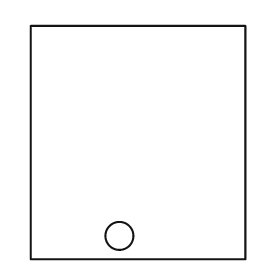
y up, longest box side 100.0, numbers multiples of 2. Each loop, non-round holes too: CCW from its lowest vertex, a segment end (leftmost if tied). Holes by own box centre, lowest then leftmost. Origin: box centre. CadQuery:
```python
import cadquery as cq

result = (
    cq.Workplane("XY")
    .moveTo(-46.0, -50.0)
    .lineTo(46.0, -50.0)
    .lineTo(46.0, 50.0)
    .lineTo(-46.0, 50.0)
    .close()
    .moveTo(-8.0, -40.0)
    .circle(6.0)
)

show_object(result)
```